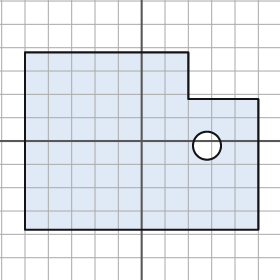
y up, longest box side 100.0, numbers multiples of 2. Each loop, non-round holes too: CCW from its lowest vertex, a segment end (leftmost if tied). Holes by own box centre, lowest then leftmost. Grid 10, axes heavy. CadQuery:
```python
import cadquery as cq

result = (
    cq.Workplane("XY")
    .moveTo(-50.0, -38.0)
    .lineTo(50.0, -38.0)
    .lineTo(50.0, 18.0)
    .lineTo(20.0, 18.0)
    .lineTo(20.0, 38.0)
    .lineTo(-50.0, 38.0)
    .close()
    .moveTo(28.0, -2.0)
    .circle(6.0)
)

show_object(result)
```